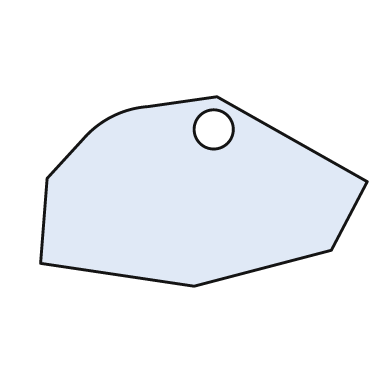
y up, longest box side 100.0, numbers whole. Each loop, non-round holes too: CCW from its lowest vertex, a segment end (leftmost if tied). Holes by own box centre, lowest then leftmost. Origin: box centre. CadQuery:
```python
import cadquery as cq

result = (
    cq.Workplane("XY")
    .moveTo(-3.0, -29.0)
    .lineTo(39.0, -18.0)
    .lineTo(50.0, 3.0)
    .lineTo(4.0, 29.0)
    .lineTo(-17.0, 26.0)
    .threePointArc((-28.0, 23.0), (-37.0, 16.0))
    .lineTo(-48.0, 4.0)
    .lineTo(-50.0, -22.0)
    .close()
    .moveTo(3.0, 19.0)
    .circle(6.0)
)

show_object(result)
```